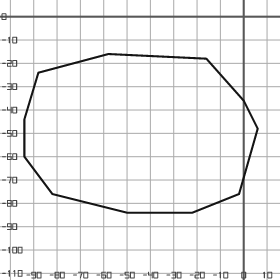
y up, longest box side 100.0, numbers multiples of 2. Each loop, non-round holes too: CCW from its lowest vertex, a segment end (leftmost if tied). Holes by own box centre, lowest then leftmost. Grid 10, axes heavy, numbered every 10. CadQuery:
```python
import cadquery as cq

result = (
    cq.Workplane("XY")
    .moveTo(-50.0, -84.0)
    .lineTo(-22.0, -84.0)
    .lineTo(-2.0, -76.0)
    .lineTo(6.0, -48.0)
    .lineTo(0.0, -36.0)
    .lineTo(-16.0, -18.0)
    .lineTo(-58.0, -16.0)
    .lineTo(-88.0, -24.0)
    .lineTo(-94.0, -44.0)
    .lineTo(-94.0, -60.0)
    .lineTo(-82.0, -76.0)
    .close()
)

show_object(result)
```